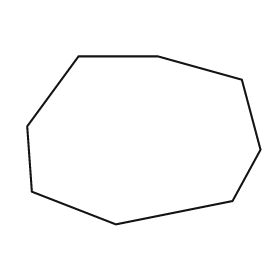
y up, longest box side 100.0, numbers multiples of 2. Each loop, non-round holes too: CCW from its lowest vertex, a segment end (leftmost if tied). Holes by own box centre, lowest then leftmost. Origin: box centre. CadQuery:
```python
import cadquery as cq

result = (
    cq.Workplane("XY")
    .moveTo(-12.0, -36.0)
    .lineTo(38.0, -26.0)
    .lineTo(50.0, -4.0)
    .lineTo(42.0, 26.0)
    .lineTo(6.0, 36.0)
    .lineTo(-28.0, 36.0)
    .lineTo(-50.0, 6.0)
    .lineTo(-48.0, -22.0)
    .close()
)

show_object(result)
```